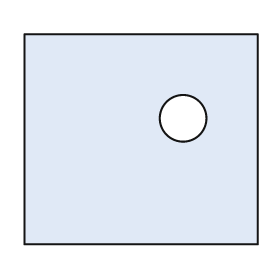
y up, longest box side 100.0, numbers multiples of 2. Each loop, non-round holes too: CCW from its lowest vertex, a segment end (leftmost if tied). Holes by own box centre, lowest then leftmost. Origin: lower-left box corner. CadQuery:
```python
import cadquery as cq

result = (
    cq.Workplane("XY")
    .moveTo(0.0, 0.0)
    .lineTo(100.0, 0.0)
    .lineTo(100.0, 90.0)
    .lineTo(0.0, 90.0)
    .close()
    .moveTo(68.0, 54.0)
    .circle(10.0)
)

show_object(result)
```